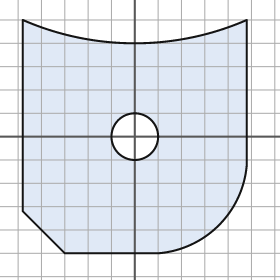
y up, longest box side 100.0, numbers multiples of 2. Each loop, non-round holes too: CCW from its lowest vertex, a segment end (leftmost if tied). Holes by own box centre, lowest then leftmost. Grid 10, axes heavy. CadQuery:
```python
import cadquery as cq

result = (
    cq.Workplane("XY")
    .moveTo(-30.0, -50.0)
    .lineTo(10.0, -50.0)
    .threePointArc((36.0, -38.0), (48.0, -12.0))
    .lineTo(48.0, 50.0)
    .threePointArc((0.0, 40.0), (-48.0, 50.0))
    .lineTo(-48.0, -32.0)
    .close()
    .moveTo(0.0, 0.0)
    .circle(10.0)
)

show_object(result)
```